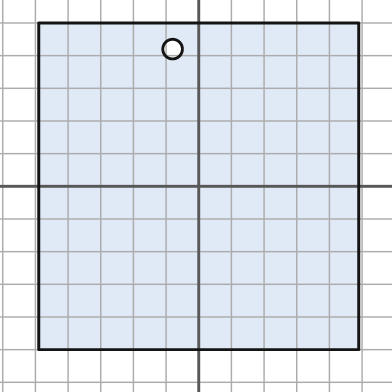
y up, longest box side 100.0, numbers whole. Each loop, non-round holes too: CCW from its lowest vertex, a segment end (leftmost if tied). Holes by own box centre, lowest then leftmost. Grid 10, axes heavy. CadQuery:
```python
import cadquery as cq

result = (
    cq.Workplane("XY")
    .moveTo(-49.0, -50.0)
    .lineTo(49.0, -50.0)
    .lineTo(49.0, 50.0)
    .lineTo(-49.0, 50.0)
    .close()
    .moveTo(-8.0, 42.0)
    .circle(3.0)
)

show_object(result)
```